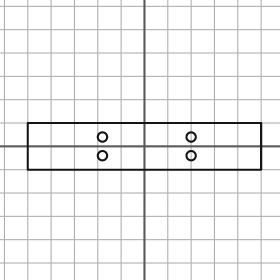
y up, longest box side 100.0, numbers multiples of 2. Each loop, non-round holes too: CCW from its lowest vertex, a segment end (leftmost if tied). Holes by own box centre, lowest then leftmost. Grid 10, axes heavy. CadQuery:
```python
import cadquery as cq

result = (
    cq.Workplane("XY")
    .moveTo(-50.0, -10.0)
    .lineTo(50.0, -10.0)
    .lineTo(50.0, 10.0)
    .lineTo(-50.0, 10.0)
    .close()
    .moveTo(-18.0, -4.0)
    .circle(2.0)
    .moveTo(20.0, -4.0)
    .circle(2.0)
    .moveTo(-18.0, 4.0)
    .circle(2.0)
    .moveTo(20.0, 4.0)
    .circle(2.0)
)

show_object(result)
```